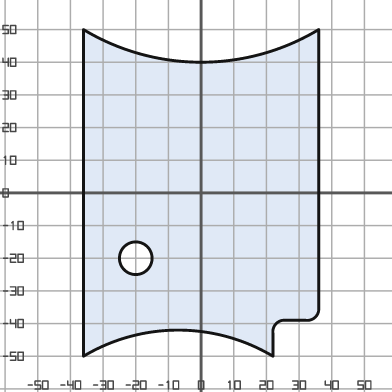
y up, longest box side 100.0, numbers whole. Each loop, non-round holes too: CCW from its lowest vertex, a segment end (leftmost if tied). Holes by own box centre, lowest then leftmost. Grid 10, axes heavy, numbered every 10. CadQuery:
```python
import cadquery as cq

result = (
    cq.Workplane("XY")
    .moveTo(-36.0, -50.0)
    .threePointArc((-7.0, -42.0), (22.0, -50.0))
    .lineTo(22.0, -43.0)
    .threePointArc((23.0, -40.0), (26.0, -39.0))
    .lineTo(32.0, -39.0)
    .threePointArc((35.0, -38.0), (36.0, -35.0))
    .lineTo(36.0, 50.0)
    .threePointArc((0.0, 40.0), (-36.0, 50.0))
    .close()
    .moveTo(-20.0, -20.0)
    .circle(5.0)
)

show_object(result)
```